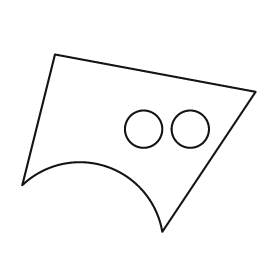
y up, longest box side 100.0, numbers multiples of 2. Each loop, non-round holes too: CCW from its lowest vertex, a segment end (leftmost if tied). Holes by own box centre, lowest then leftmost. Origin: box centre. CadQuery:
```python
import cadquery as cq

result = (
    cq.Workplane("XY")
    .moveTo(10.0, -38.0)
    .lineTo(50.0, 22.0)
    .lineTo(-36.0, 38.0)
    .lineTo(-50.0, -18.0)
    .threePointArc((-14.0, -10.0), (10.0, -38.0))
    .close()
    .moveTo(2.0, 6.0)
    .circle(8.0)
    .moveTo(22.0, 6.0)
    .circle(8.0)
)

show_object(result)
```